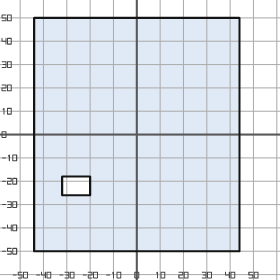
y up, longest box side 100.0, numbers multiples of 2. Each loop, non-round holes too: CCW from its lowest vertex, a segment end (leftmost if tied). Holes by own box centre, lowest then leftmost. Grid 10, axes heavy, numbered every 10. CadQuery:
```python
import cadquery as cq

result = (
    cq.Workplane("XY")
    .moveTo(-44.0, -50.0)
    .lineTo(44.0, -50.0)
    .lineTo(44.0, 50.0)
    .lineTo(-44.0, 50.0)
    .close()
    .moveTo(-32.0, -26.0)
    .lineTo(-20.0, -26.0)
    .lineTo(-20.0, -18.0)
    .lineTo(-32.0, -18.0)
    .close()
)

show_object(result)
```